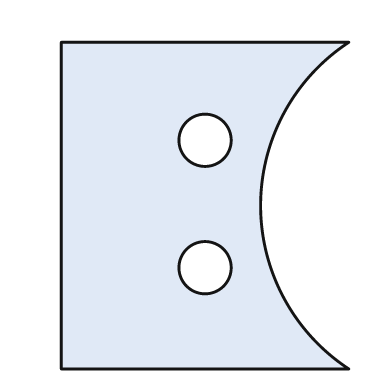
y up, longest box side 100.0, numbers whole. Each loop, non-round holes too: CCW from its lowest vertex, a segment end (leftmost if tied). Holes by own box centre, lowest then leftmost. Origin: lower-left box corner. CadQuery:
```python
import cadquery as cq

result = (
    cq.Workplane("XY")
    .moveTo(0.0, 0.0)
    .lineTo(88.0, 0.0)
    .threePointArc((61.0, 50.0), (88.0, 100.0))
    .lineTo(0.0, 100.0)
    .close()
    .moveTo(44.0, 31.0)
    .circle(8.0)
    .moveTo(44.0, 70.0)
    .circle(8.0)
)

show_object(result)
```